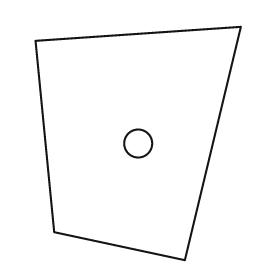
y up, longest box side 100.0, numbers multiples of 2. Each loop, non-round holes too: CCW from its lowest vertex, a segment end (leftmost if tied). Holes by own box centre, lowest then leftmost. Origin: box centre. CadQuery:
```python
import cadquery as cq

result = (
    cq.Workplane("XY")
    .moveTo(20.0, -50.0)
    .lineTo(44.0, 50.0)
    .lineTo(-44.0, 44.0)
    .lineTo(-36.0, -38.0)
    .close()
    .moveTo(0.0, 0.0)
    .circle(6.0)
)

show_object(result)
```